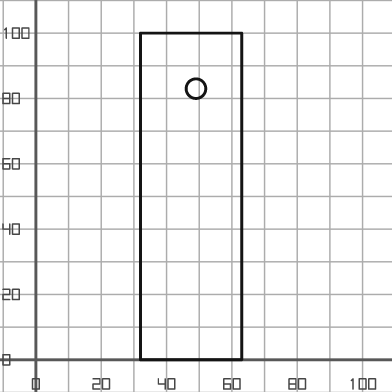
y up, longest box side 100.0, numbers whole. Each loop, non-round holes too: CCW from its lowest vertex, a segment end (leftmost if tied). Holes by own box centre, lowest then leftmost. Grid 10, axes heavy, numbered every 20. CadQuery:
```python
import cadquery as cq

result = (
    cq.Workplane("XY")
    .moveTo(32.0, 0.0)
    .lineTo(63.0, 0.0)
    .lineTo(63.0, 100.0)
    .lineTo(32.0, 100.0)
    .close()
    .moveTo(49.0, 83.0)
    .circle(3.0)
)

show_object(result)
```